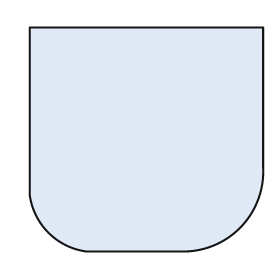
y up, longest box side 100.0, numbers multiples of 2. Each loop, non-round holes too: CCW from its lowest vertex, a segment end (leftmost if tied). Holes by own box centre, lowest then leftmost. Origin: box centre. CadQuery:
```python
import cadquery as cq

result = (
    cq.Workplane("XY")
    .moveTo(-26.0, -48.0)
    .lineTo(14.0, -48.0)
    .threePointArc((40.0, -38.0), (50.0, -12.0))
    .lineTo(50.0, 48.0)
    .lineTo(-50.0, 48.0)
    .lineTo(-50.0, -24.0)
    .threePointArc((-42.0, -40.0), (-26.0, -48.0))
    .close()
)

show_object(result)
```